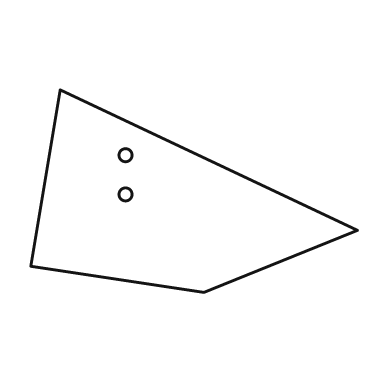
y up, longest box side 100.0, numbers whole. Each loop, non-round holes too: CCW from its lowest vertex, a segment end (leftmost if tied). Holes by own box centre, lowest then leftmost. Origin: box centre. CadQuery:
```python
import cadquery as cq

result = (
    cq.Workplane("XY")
    .moveTo(3.0, -31.0)
    .lineTo(50.0, -12.0)
    .lineTo(-41.0, 31.0)
    .lineTo(-50.0, -23.0)
    .close()
    .moveTo(-21.0, -1.0)
    .circle(2.0)
    .moveTo(-21.0, 11.0)
    .circle(2.0)
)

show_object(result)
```